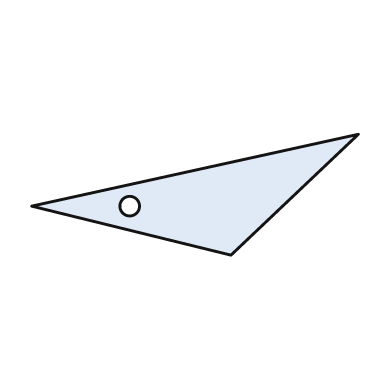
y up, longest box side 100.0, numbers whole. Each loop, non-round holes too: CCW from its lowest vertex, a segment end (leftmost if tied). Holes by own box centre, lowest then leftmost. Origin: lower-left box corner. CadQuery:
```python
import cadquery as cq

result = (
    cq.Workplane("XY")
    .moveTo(61.0, 0.0)
    .lineTo(100.0, 37.0)
    .lineTo(0.0, 15.0)
    .close()
    .moveTo(30.0, 15.0)
    .circle(3.0)
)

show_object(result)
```